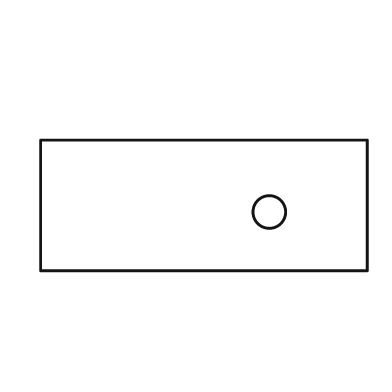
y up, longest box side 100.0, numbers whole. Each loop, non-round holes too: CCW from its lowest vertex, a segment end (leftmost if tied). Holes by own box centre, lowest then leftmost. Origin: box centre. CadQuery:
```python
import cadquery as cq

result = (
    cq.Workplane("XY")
    .moveTo(-50.0, -20.0)
    .lineTo(50.0, -20.0)
    .lineTo(50.0, 20.0)
    .lineTo(-50.0, 20.0)
    .close()
    .moveTo(20.0, -2.0)
    .circle(5.0)
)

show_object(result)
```